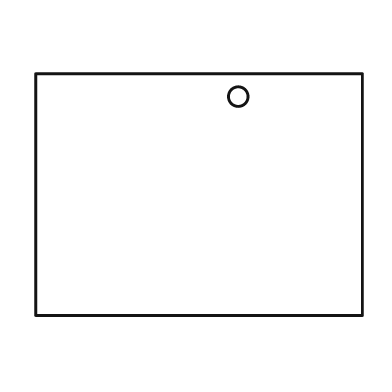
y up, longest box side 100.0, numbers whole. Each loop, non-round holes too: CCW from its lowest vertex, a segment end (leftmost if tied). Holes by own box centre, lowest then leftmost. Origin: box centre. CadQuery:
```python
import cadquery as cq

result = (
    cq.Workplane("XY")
    .moveTo(-50.0, -37.0)
    .lineTo(50.0, -37.0)
    .lineTo(50.0, 37.0)
    .lineTo(-50.0, 37.0)
    .close()
    .moveTo(12.0, 30.0)
    .circle(3.0)
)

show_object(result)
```